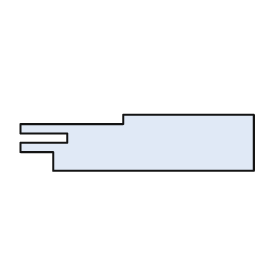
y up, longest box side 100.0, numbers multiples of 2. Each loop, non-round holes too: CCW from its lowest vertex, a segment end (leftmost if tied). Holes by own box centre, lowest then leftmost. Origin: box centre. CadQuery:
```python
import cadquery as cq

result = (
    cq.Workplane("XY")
    .moveTo(-36.0, -12.0)
    .lineTo(50.0, -12.0)
    .lineTo(50.0, 12.0)
    .lineTo(-6.0, 12.0)
    .lineTo(-6.0, 8.0)
    .lineTo(-50.0, 8.0)
    .lineTo(-50.0, 4.0)
    .lineTo(-30.0, 4.0)
    .lineTo(-30.0, 0.0)
    .lineTo(-50.0, 0.0)
    .lineTo(-50.0, -4.0)
    .lineTo(-36.0, -4.0)
    .close()
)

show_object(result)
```